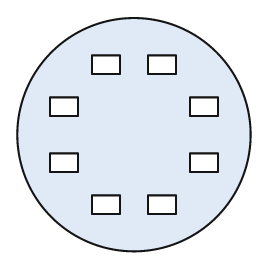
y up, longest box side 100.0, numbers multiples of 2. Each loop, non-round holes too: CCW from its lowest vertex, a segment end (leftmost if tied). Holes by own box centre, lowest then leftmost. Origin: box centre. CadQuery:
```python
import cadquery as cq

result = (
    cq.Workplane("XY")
    .moveTo(0.0, 0.0)
    .circle(50.0)
    .moveTo(-18.0, -34.0)
    .lineTo(-6.0, -34.0)
    .lineTo(-6.0, -26.0)
    .lineTo(-18.0, -26.0)
    .close()
    .moveTo(6.0, -34.0)
    .lineTo(18.0, -34.0)
    .lineTo(18.0, -26.0)
    .lineTo(6.0, -26.0)
    .close()
    .moveTo(-36.0, -16.0)
    .lineTo(-24.0, -16.0)
    .lineTo(-24.0, -8.0)
    .lineTo(-36.0, -8.0)
    .close()
    .moveTo(24.0, -16.0)
    .lineTo(36.0, -16.0)
    .lineTo(36.0, -8.0)
    .lineTo(24.0, -8.0)
    .close()
    .moveTo(-36.0, 8.0)
    .lineTo(-24.0, 8.0)
    .lineTo(-24.0, 16.0)
    .lineTo(-36.0, 16.0)
    .close()
    .moveTo(24.0, 8.0)
    .lineTo(36.0, 8.0)
    .lineTo(36.0, 16.0)
    .lineTo(24.0, 16.0)
    .close()
    .moveTo(-18.0, 26.0)
    .lineTo(-6.0, 26.0)
    .lineTo(-6.0, 34.0)
    .lineTo(-18.0, 34.0)
    .close()
    .moveTo(6.0, 26.0)
    .lineTo(18.0, 26.0)
    .lineTo(18.0, 34.0)
    .lineTo(6.0, 34.0)
    .close()
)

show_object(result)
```